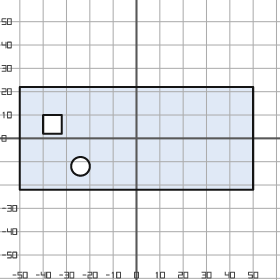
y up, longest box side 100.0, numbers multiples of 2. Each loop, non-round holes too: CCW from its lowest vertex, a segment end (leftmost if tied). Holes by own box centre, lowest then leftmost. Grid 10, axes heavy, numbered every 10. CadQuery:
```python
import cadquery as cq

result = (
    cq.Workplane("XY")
    .moveTo(-50.0, -22.0)
    .lineTo(50.0, -22.0)
    .lineTo(50.0, 22.0)
    .lineTo(-50.0, 22.0)
    .close()
    .moveTo(-24.0, -12.0)
    .circle(4.0)
    .moveTo(-40.0, 2.0)
    .lineTo(-32.0, 2.0)
    .lineTo(-32.0, 10.0)
    .lineTo(-40.0, 10.0)
    .close()
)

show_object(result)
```